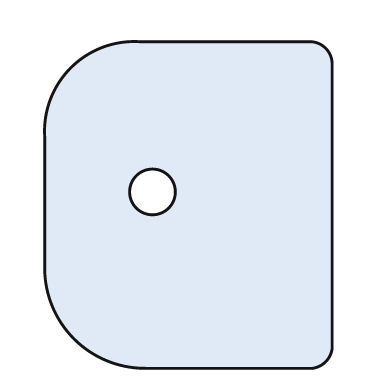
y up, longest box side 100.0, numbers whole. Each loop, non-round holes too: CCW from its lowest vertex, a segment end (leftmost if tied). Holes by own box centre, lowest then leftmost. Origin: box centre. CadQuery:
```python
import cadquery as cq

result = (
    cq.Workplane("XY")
    .moveTo(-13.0, -50.0)
    .lineTo(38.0, -50.0)
    .threePointArc((42.0, -48.0), (44.0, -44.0))
    .lineTo(44.0, 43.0)
    .threePointArc((42.0, 48.0), (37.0, 50.0))
    .lineTo(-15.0, 50.0)
    .threePointArc((-36.0, 42.0), (-44.0, 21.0))
    .lineTo(-44.0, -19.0)
    .threePointArc((-35.0, -41.0), (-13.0, -50.0))
    .close()
    .moveTo(-11.0, 4.0)
    .circle(7.0)
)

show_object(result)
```